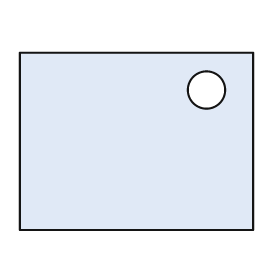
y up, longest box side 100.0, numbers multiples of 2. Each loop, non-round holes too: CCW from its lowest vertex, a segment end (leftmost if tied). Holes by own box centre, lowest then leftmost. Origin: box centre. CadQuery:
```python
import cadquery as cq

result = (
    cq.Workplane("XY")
    .moveTo(-50.0, -38.0)
    .lineTo(50.0, -38.0)
    .lineTo(50.0, 38.0)
    .lineTo(-50.0, 38.0)
    .close()
    .moveTo(30.0, 22.0)
    .circle(8.0)
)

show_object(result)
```